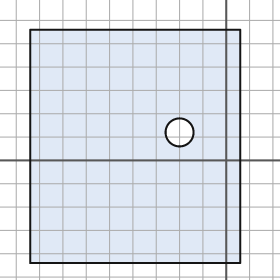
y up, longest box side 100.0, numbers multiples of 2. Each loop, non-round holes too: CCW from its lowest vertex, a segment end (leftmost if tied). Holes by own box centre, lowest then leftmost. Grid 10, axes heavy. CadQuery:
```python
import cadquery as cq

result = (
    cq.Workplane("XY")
    .moveTo(-84.0, -44.0)
    .lineTo(6.0, -44.0)
    .lineTo(6.0, 56.0)
    .lineTo(-84.0, 56.0)
    .close()
    .moveTo(-20.0, 12.0)
    .circle(6.0)
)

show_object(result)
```